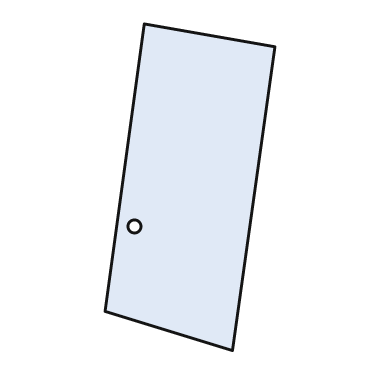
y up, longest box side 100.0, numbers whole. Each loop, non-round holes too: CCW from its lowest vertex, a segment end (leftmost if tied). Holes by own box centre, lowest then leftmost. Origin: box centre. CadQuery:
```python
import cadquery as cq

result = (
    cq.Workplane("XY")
    .moveTo(13.0, -50.0)
    .lineTo(26.0, 43.0)
    .lineTo(-14.0, 50.0)
    .lineTo(-26.0, -38.0)
    .close()
    .moveTo(-17.0, -12.0)
    .circle(2.0)
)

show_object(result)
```